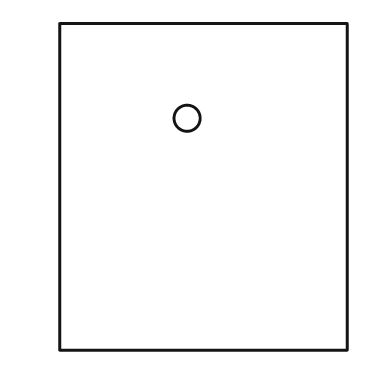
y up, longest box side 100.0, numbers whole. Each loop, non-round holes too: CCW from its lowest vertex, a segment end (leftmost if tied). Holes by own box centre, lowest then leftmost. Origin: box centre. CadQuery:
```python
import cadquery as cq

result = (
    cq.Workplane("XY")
    .moveTo(-44.0, -50.0)
    .lineTo(44.0, -50.0)
    .lineTo(44.0, 50.0)
    .lineTo(-44.0, 50.0)
    .close()
    .moveTo(-5.0, 21.0)
    .circle(4.0)
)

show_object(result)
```